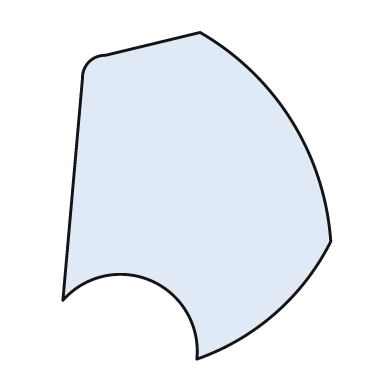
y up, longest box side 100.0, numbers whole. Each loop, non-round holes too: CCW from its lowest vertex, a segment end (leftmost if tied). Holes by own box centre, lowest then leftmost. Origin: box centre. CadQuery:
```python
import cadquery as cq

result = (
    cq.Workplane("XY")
    .moveTo(0.0, -50.0)
    .threePointArc((24.0, -36.0), (41.0, -14.0))
    .threePointArc((29.0, 23.0), (1.0, 50.0))
    .lineTo(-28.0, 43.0)
    .threePointArc((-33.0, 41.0), (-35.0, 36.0))
    .lineTo(-41.0, -32.0)
    .threePointArc((-14.0, -26.0), (0.0, -50.0))
    .close()
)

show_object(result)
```